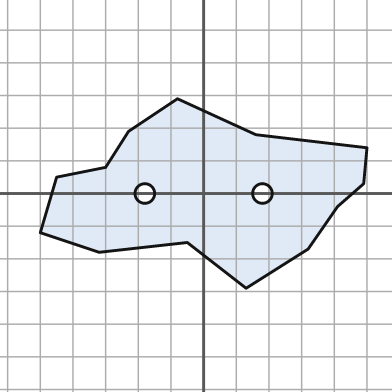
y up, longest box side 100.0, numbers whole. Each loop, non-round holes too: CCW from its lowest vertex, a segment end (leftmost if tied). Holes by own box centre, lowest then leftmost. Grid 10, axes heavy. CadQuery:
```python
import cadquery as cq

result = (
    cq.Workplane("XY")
    .moveTo(13.0, -29.0)
    .lineTo(32.0, -17.0)
    .lineTo(41.0, -4.0)
    .lineTo(49.0, 3.0)
    .lineTo(50.0, 14.0)
    .lineTo(16.0, 18.0)
    .lineTo(-8.0, 29.0)
    .lineTo(-23.0, 19.0)
    .lineTo(-30.0, 8.0)
    .lineTo(-45.0, 5.0)
    .lineTo(-50.0, -12.0)
    .lineTo(-32.0, -18.0)
    .lineTo(-5.0, -15.0)
    .close()
    .moveTo(-18.0, 0.0)
    .circle(3.0)
    .moveTo(18.0, 0.0)
    .circle(3.0)
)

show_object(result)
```